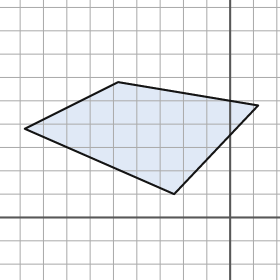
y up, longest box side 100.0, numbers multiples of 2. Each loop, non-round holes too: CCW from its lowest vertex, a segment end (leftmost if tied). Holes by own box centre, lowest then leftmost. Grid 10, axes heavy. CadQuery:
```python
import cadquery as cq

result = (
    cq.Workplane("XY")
    .moveTo(-24.0, 10.0)
    .lineTo(12.0, 48.0)
    .lineTo(-48.0, 58.0)
    .lineTo(-88.0, 38.0)
    .close()
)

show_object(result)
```